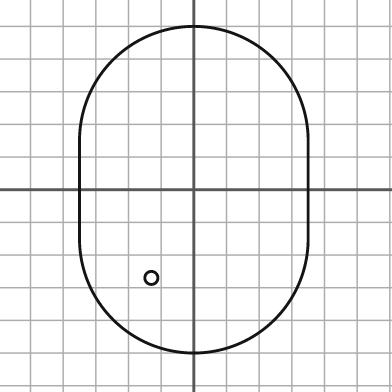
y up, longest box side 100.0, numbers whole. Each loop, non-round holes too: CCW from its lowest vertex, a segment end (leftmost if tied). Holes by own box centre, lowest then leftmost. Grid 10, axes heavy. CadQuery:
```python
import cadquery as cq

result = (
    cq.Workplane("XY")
    .moveTo(-35.0, -15.0)
    .threePointArc((0.0, -50.0), (35.0, -15.0))
    .lineTo(35.0, 15.0)
    .threePointArc((0.0, 50.0), (-35.0, 15.0))
    .close()
    .moveTo(-13.0, -27.0)
    .circle(2.0)
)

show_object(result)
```